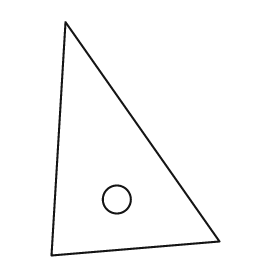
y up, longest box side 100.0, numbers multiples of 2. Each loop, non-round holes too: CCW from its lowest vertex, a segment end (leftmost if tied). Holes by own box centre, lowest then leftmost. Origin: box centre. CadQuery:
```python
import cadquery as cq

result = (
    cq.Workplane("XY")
    .moveTo(-36.0, -50.0)
    .lineTo(36.0, -44.0)
    .lineTo(-30.0, 50.0)
    .close()
    .moveTo(-8.0, -26.0)
    .circle(6.0)
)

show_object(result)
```